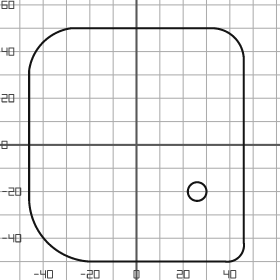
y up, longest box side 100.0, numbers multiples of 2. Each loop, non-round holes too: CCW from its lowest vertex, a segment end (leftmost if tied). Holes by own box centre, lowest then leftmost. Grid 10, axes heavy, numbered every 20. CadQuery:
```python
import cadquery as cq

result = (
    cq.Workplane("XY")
    .moveTo(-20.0, -50.0)
    .lineTo(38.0, -50.0)
    .threePointArc((44.0, -48.0), (46.0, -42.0))
    .lineTo(46.0, 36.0)
    .threePointArc((42.0, 46.0), (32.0, 50.0))
    .lineTo(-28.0, 50.0)
    .threePointArc((-40.0, 44.0), (-46.0, 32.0))
    .lineTo(-46.0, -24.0)
    .threePointArc((-38.0, -42.0), (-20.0, -50.0))
    .close()
    .moveTo(26.0, -20.0)
    .circle(4.0)
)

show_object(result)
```